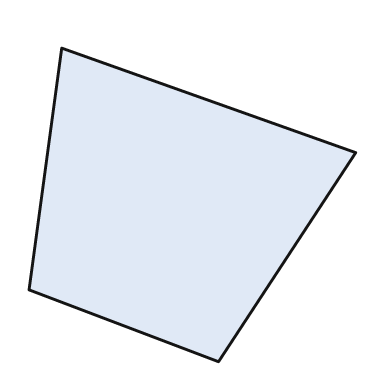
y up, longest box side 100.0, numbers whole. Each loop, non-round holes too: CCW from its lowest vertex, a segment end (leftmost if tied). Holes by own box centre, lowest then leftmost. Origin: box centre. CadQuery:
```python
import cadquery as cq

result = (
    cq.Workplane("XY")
    .moveTo(8.0, -48.0)
    .lineTo(50.0, 16.0)
    .lineTo(-40.0, 48.0)
    .lineTo(-50.0, -26.0)
    .close()
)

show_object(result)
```